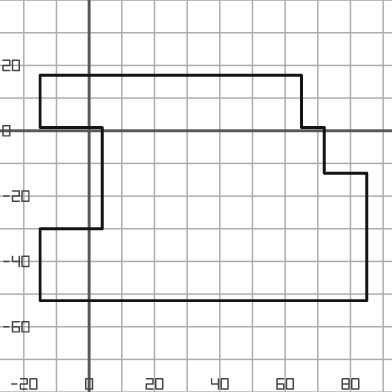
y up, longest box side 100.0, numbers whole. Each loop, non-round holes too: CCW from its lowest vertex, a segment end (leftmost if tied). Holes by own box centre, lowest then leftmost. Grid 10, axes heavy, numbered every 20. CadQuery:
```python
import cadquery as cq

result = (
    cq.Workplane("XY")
    .moveTo(-15.0, -52.0)
    .lineTo(85.0, -52.0)
    .lineTo(85.0, -13.0)
    .lineTo(72.0, -13.0)
    .lineTo(72.0, 1.0)
    .lineTo(65.0, 1.0)
    .lineTo(65.0, 17.0)
    .lineTo(-15.0, 17.0)
    .lineTo(-15.0, 1.0)
    .lineTo(4.0, 1.0)
    .lineTo(4.0, -30.0)
    .lineTo(-15.0, -30.0)
    .close()
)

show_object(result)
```